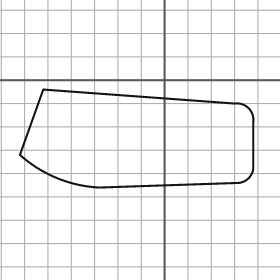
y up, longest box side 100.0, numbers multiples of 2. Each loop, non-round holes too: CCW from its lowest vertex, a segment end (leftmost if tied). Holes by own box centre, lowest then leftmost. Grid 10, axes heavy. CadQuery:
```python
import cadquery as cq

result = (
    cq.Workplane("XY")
    .moveTo(-28.0, -46.0)
    .lineTo(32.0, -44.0)
    .threePointArc((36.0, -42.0), (38.0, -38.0))
    .lineTo(38.0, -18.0)
    .threePointArc((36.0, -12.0), (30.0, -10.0))
    .lineTo(-52.0, -4.0)
    .lineTo(-62.0, -32.0)
    .threePointArc((-46.0, -42.0), (-28.0, -46.0))
    .close()
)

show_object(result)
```